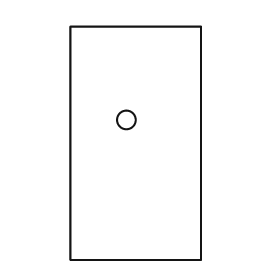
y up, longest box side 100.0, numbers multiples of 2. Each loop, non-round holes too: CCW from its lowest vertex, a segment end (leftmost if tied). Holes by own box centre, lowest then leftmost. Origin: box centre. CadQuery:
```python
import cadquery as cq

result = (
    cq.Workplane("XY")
    .moveTo(-28.0, -50.0)
    .lineTo(28.0, -50.0)
    .lineTo(28.0, 50.0)
    .lineTo(-28.0, 50.0)
    .close()
    .moveTo(-4.0, 10.0)
    .circle(4.0)
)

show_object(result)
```